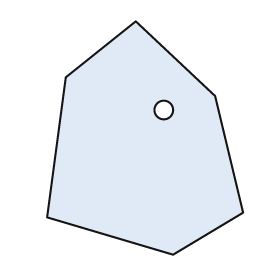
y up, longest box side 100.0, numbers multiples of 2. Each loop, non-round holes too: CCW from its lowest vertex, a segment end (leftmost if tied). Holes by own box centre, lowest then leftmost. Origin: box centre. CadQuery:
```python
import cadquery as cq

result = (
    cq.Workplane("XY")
    .moveTo(12.0, -50.0)
    .lineTo(42.0, -32.0)
    .lineTo(30.0, 18.0)
    .lineTo(-4.0, 50.0)
    .lineTo(-34.0, 26.0)
    .lineTo(-42.0, -34.0)
    .close()
    .moveTo(8.0, 12.0)
    .circle(4.0)
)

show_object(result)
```